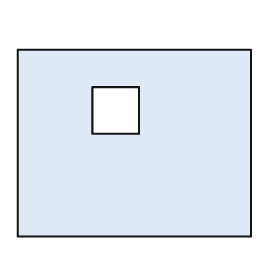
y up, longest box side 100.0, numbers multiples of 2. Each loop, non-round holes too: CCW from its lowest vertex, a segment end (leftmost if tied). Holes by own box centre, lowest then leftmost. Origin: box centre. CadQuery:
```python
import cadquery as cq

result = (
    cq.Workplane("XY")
    .moveTo(-50.0, -40.0)
    .lineTo(50.0, -40.0)
    .lineTo(50.0, 40.0)
    .lineTo(-50.0, 40.0)
    .close()
    .moveTo(-18.0, 4.0)
    .lineTo(2.0, 4.0)
    .lineTo(2.0, 24.0)
    .lineTo(-18.0, 24.0)
    .close()
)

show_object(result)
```